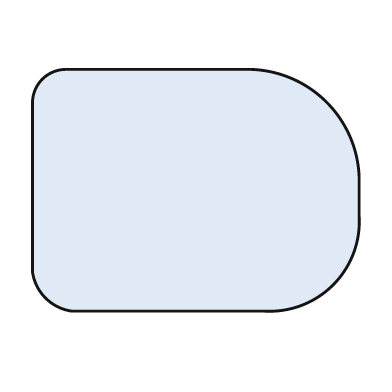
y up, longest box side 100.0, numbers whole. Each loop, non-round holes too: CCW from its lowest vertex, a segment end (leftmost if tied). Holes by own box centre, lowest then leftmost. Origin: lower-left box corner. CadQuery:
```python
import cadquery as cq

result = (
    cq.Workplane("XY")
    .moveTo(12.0, 0.0)
    .lineTo(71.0, 0.0)
    .threePointArc((92.0, 8.0), (100.0, 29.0))
    .lineTo(100.0, 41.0)
    .threePointArc((90.0, 64.0), (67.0, 74.0))
    .lineTo(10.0, 74.0)
    .threePointArc((3.0, 71.0), (0.0, 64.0))
    .lineTo(0.0, 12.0)
    .threePointArc((4.0, 4.0), (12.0, 0.0))
    .close()
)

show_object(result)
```